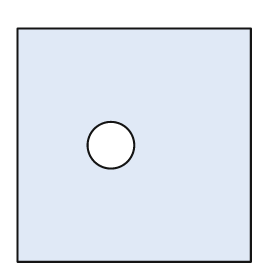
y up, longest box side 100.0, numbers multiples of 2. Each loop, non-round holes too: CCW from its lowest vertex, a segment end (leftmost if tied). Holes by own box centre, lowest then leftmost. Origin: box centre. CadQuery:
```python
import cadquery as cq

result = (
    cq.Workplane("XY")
    .moveTo(-50.0, -50.0)
    .lineTo(50.0, -50.0)
    .lineTo(50.0, 50.0)
    .lineTo(-50.0, 50.0)
    .close()
    .moveTo(-10.0, 0.0)
    .circle(10.0)
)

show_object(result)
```